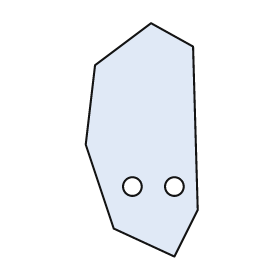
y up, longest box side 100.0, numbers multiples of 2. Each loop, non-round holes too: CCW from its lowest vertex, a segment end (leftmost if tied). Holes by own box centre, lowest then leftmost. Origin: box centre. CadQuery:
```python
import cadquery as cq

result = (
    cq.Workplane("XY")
    .moveTo(14.0, -50.0)
    .lineTo(24.0, -30.0)
    .lineTo(22.0, 40.0)
    .lineTo(4.0, 50.0)
    .lineTo(-20.0, 32.0)
    .lineTo(-24.0, -2.0)
    .lineTo(-12.0, -38.0)
    .close()
    .moveTo(-4.0, -20.0)
    .circle(4.0)
    .moveTo(14.0, -20.0)
    .circle(4.0)
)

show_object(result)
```